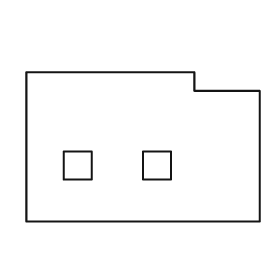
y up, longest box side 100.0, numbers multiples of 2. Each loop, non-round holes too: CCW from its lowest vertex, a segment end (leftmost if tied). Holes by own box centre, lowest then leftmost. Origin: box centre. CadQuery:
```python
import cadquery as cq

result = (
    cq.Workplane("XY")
    .moveTo(-50.0, -32.0)
    .lineTo(50.0, -32.0)
    .lineTo(50.0, 24.0)
    .lineTo(22.0, 24.0)
    .lineTo(22.0, 32.0)
    .lineTo(-50.0, 32.0)
    .close()
    .moveTo(-34.0, -14.0)
    .lineTo(-22.0, -14.0)
    .lineTo(-22.0, -2.0)
    .lineTo(-34.0, -2.0)
    .close()
    .moveTo(0.0, -14.0)
    .lineTo(12.0, -14.0)
    .lineTo(12.0, -2.0)
    .lineTo(0.0, -2.0)
    .close()
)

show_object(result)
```